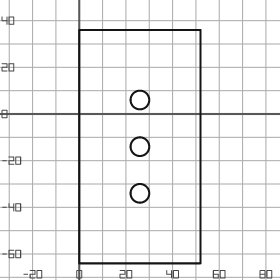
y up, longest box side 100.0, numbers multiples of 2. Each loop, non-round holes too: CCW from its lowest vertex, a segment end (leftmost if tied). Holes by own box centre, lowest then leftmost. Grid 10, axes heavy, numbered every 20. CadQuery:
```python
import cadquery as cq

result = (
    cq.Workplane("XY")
    .moveTo(0.0, -64.0)
    .lineTo(52.0, -64.0)
    .lineTo(52.0, 36.0)
    .lineTo(0.0, 36.0)
    .close()
    .moveTo(26.0, -34.0)
    .circle(4.0)
    .moveTo(26.0, -14.0)
    .circle(4.0)
    .moveTo(26.0, 6.0)
    .circle(4.0)
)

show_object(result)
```